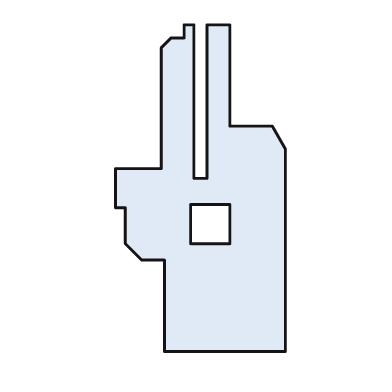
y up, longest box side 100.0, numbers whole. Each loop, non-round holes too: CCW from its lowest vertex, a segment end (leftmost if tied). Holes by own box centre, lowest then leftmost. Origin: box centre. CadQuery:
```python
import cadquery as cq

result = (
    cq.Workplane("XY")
    .moveTo(-11.0, -50.0)
    .lineTo(26.0, -50.0)
    .lineTo(26.0, 12.0)
    .lineTo(22.0, 19.0)
    .lineTo(9.0, 19.0)
    .lineTo(9.0, 50.0)
    .lineTo(2.0, 50.0)
    .lineTo(2.0, 3.0)
    .lineTo(-2.0, 3.0)
    .lineTo(-2.0, 50.0)
    .lineTo(-5.0, 50.0)
    .lineTo(-5.0, 46.0)
    .lineTo(-9.0, 46.0)
    .lineTo(-12.0, 43.0)
    .lineTo(-12.0, 6.0)
    .lineTo(-26.0, 6.0)
    .lineTo(-26.0, -6.0)
    .lineTo(-23.0, -6.0)
    .lineTo(-23.0, -17.0)
    .lineTo(-18.0, -22.0)
    .lineTo(-11.0, -22.0)
    .close()
    .moveTo(-3.0, -17.0)
    .lineTo(9.0, -17.0)
    .lineTo(9.0, -5.0)
    .lineTo(-3.0, -5.0)
    .close()
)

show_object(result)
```